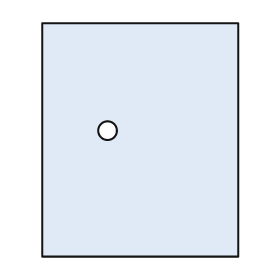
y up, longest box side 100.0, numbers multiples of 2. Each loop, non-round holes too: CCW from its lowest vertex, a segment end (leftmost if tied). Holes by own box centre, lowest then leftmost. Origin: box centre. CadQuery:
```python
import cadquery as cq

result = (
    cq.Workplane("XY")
    .moveTo(-42.0, -50.0)
    .lineTo(42.0, -50.0)
    .lineTo(42.0, 50.0)
    .lineTo(-42.0, 50.0)
    .close()
    .moveTo(-14.0, 4.0)
    .circle(4.0)
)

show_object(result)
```